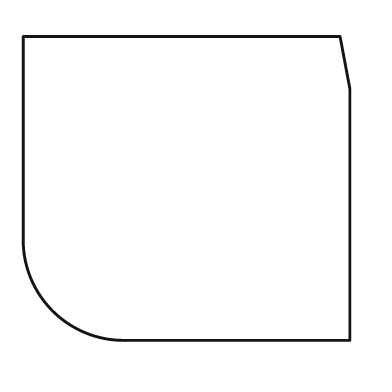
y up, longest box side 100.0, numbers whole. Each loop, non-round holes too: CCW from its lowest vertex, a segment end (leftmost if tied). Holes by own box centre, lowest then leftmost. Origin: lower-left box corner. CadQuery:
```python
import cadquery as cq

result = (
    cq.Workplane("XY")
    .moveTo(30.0, 0.0)
    .lineTo(100.0, 0.0)
    .lineTo(100.0, 77.0)
    .lineTo(97.0, 93.0)
    .lineTo(0.0, 93.0)
    .lineTo(0.0, 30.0)
    .threePointArc((9.0, 9.0), (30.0, 0.0))
    .close()
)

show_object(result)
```